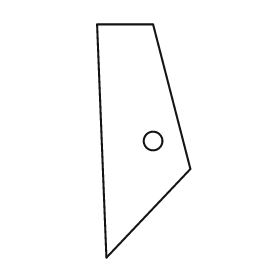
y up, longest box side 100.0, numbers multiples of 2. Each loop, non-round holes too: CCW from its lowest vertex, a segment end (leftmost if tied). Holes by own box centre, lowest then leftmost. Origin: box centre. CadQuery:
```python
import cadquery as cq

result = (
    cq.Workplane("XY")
    .moveTo(-16.0, -50.0)
    .lineTo(20.0, -12.0)
    .lineTo(4.0, 50.0)
    .lineTo(-20.0, 50.0)
    .close()
    .moveTo(4.0, 0.0)
    .circle(4.0)
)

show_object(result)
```